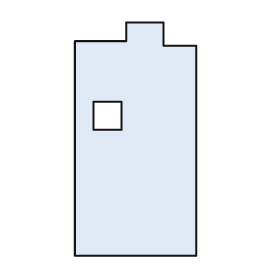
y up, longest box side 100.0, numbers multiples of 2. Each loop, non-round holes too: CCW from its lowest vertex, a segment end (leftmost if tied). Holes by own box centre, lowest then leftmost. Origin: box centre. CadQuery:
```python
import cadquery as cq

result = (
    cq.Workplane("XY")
    .moveTo(-26.0, -50.0)
    .lineTo(26.0, -50.0)
    .lineTo(26.0, 40.0)
    .lineTo(12.0, 40.0)
    .lineTo(12.0, 50.0)
    .lineTo(-4.0, 50.0)
    .lineTo(-4.0, 42.0)
    .lineTo(-26.0, 42.0)
    .close()
    .moveTo(-18.0, 4.0)
    .lineTo(-6.0, 4.0)
    .lineTo(-6.0, 16.0)
    .lineTo(-18.0, 16.0)
    .close()
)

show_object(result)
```